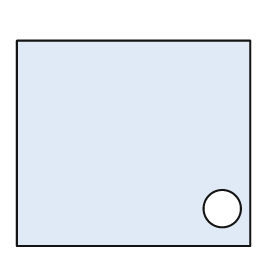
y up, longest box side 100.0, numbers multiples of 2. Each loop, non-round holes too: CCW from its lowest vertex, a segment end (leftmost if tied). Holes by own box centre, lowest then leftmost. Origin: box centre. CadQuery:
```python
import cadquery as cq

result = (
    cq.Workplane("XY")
    .moveTo(-50.0, -44.0)
    .lineTo(50.0, -44.0)
    .lineTo(50.0, 44.0)
    .lineTo(-50.0, 44.0)
    .close()
    .moveTo(38.0, -28.0)
    .circle(8.0)
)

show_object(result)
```